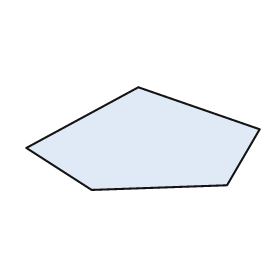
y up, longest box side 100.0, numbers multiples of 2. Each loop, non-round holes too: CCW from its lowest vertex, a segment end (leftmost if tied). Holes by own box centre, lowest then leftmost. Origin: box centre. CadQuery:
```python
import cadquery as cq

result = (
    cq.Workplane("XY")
    .moveTo(-22.0, -22.0)
    .lineTo(36.0, -20.0)
    .lineTo(50.0, 4.0)
    .lineTo(-2.0, 22.0)
    .lineTo(-50.0, -4.0)
    .close()
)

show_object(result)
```